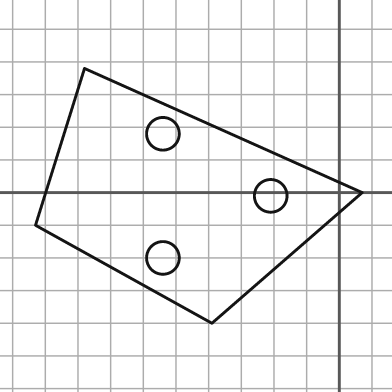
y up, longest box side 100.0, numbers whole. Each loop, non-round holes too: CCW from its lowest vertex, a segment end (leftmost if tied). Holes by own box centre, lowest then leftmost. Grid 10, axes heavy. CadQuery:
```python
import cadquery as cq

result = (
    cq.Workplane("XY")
    .moveTo(-39.0, -40.0)
    .lineTo(7.0, 0.0)
    .lineTo(-78.0, 38.0)
    .lineTo(-93.0, -10.0)
    .close()
    .moveTo(-54.0, -20.0)
    .circle(5.0)
    .moveTo(-21.0, -1.0)
    .circle(5.0)
    .moveTo(-54.0, 18.0)
    .circle(5.0)
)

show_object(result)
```